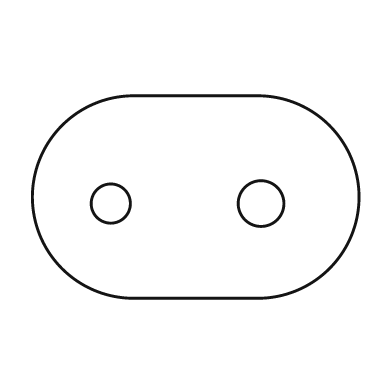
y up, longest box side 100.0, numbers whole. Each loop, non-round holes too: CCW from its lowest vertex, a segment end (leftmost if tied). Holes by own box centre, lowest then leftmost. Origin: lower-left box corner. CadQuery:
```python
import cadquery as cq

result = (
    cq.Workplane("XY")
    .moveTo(31.0, 0.0)
    .lineTo(69.0, 0.0)
    .threePointArc((100.0, 31.0), (69.0, 62.0))
    .lineTo(31.0, 62.0)
    .threePointArc((0.0, 31.0), (31.0, 0.0))
    .close()
    .moveTo(24.0, 29.0)
    .circle(6.0)
    .moveTo(70.0, 29.0)
    .circle(7.0)
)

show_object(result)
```